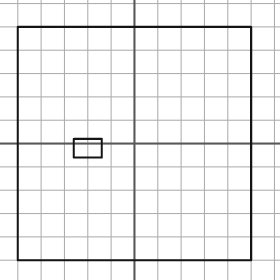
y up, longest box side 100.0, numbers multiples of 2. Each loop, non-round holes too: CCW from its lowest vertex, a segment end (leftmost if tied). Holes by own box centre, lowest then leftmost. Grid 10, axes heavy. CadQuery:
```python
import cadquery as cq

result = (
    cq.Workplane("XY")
    .moveTo(-50.0, -50.0)
    .lineTo(50.0, -50.0)
    .lineTo(50.0, 50.0)
    .lineTo(-50.0, 50.0)
    .close()
    .moveTo(-26.0, -6.0)
    .lineTo(-14.0, -6.0)
    .lineTo(-14.0, 2.0)
    .lineTo(-26.0, 2.0)
    .close()
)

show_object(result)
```